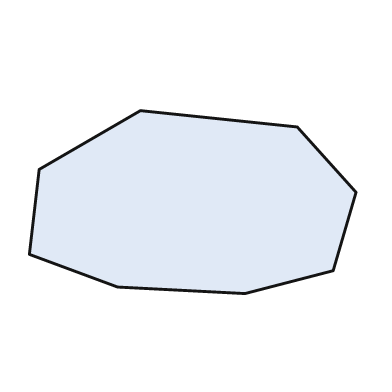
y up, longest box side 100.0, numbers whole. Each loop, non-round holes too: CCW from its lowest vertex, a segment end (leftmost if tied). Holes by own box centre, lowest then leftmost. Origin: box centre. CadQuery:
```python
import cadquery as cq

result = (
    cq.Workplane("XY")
    .moveTo(16.0, -28.0)
    .lineTo(43.0, -21.0)
    .lineTo(50.0, 3.0)
    .lineTo(32.0, 23.0)
    .lineTo(-16.0, 28.0)
    .lineTo(-47.0, 10.0)
    .lineTo(-50.0, -16.0)
    .lineTo(-23.0, -26.0)
    .close()
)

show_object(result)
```